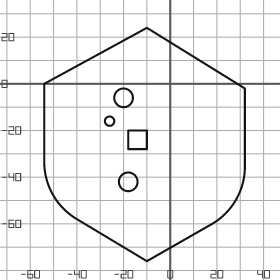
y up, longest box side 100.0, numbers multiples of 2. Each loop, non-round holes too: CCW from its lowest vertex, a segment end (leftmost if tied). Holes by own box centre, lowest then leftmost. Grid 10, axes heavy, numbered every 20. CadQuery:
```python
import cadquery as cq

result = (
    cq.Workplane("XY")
    .moveTo(-10.0, -76.0)
    .lineTo(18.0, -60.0)
    .threePointArc((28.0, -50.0), (32.0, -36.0))
    .lineTo(32.0, -2.0)
    .lineTo(-10.0, 24.0)
    .lineTo(-54.0, 0.0)
    .lineTo(-54.0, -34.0)
    .threePointArc((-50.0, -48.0), (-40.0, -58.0))
    .close()
    .moveTo(-18.0, -42.0)
    .circle(4.0)
    .moveTo(-18.0, -28.0)
    .lineTo(-10.0, -28.0)
    .lineTo(-10.0, -20.0)
    .lineTo(-18.0, -20.0)
    .close()
    .moveTo(-26.0, -16.0)
    .circle(2.0)
    .moveTo(-20.0, -6.0)
    .circle(4.0)
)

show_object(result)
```